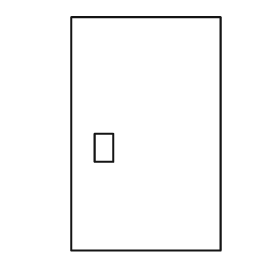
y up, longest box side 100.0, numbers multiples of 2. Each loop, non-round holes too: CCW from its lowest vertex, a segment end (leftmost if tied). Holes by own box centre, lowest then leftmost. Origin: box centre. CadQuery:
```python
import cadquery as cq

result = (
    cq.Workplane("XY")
    .moveTo(-32.0, -50.0)
    .lineTo(32.0, -50.0)
    .lineTo(32.0, 50.0)
    .lineTo(-32.0, 50.0)
    .close()
    .moveTo(-22.0, -12.0)
    .lineTo(-14.0, -12.0)
    .lineTo(-14.0, 0.0)
    .lineTo(-22.0, 0.0)
    .close()
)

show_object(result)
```